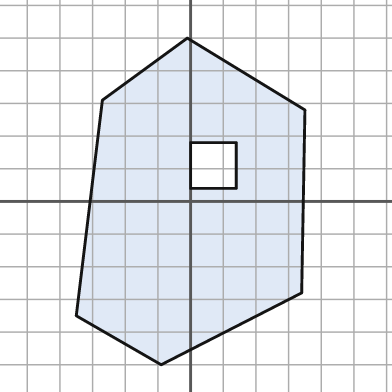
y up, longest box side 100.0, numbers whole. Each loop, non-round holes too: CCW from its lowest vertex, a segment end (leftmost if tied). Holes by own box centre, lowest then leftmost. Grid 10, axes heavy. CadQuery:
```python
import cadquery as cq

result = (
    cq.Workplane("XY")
    .moveTo(-9.0, -50.0)
    .lineTo(34.0, -28.0)
    .lineTo(35.0, 28.0)
    .lineTo(-1.0, 50.0)
    .lineTo(-27.0, 31.0)
    .lineTo(-35.0, -35.0)
    .close()
    .moveTo(0.0, 4.0)
    .lineTo(14.0, 4.0)
    .lineTo(14.0, 18.0)
    .lineTo(0.0, 18.0)
    .close()
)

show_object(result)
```